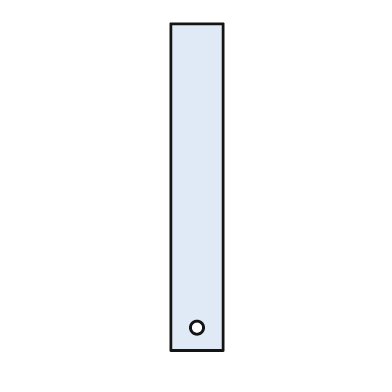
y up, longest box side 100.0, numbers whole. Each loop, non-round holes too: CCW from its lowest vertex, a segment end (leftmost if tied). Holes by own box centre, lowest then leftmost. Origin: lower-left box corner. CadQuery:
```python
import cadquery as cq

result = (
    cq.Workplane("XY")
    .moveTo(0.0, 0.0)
    .lineTo(16.0, 0.0)
    .lineTo(16.0, 100.0)
    .lineTo(0.0, 100.0)
    .close()
    .moveTo(8.0, 7.0)
    .circle(2.0)
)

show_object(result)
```